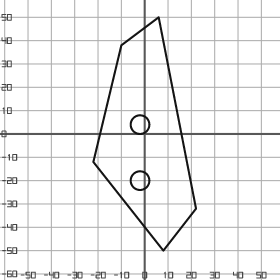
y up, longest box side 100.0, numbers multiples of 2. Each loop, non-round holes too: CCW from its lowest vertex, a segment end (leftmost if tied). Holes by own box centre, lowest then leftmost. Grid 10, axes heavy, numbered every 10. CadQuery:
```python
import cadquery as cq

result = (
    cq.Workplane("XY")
    .moveTo(8.0, -50.0)
    .lineTo(22.0, -32.0)
    .lineTo(6.0, 50.0)
    .lineTo(-10.0, 38.0)
    .lineTo(-22.0, -12.0)
    .close()
    .moveTo(-2.0, -20.0)
    .circle(4.0)
    .moveTo(-2.0, 4.0)
    .circle(4.0)
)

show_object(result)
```